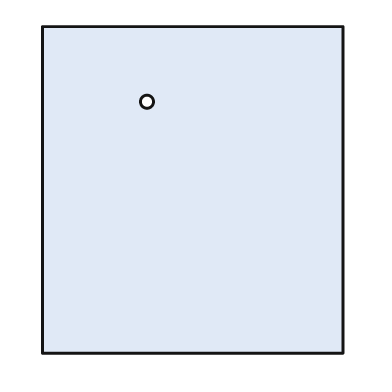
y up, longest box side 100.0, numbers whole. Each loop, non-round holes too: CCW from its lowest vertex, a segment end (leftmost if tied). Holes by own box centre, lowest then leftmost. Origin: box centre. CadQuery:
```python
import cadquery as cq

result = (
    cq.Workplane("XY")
    .moveTo(-46.0, -50.0)
    .lineTo(46.0, -50.0)
    .lineTo(46.0, 50.0)
    .lineTo(-46.0, 50.0)
    .close()
    .moveTo(-14.0, 27.0)
    .circle(2.0)
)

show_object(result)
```